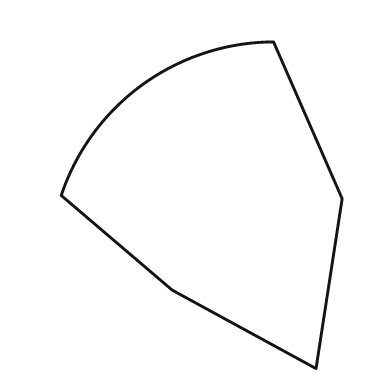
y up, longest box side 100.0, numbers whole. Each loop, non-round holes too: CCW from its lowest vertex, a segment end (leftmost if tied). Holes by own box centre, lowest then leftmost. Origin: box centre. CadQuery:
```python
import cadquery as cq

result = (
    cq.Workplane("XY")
    .moveTo(35.0, -50.0)
    .lineTo(43.0, 2.0)
    .lineTo(22.0, 50.0)
    .threePointArc((-18.0, 37.0), (-43.0, 3.0))
    .lineTo(-9.0, -26.0)
    .close()
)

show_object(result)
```